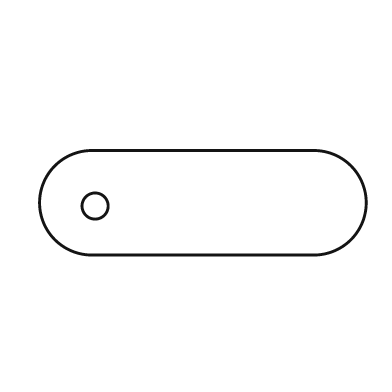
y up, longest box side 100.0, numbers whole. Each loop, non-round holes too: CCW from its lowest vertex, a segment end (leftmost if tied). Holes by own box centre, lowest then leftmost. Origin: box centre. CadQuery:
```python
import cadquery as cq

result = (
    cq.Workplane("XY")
    .moveTo(-34.0, -16.0)
    .lineTo(34.0, -16.0)
    .threePointArc((50.0, 0.0), (34.0, 16.0))
    .lineTo(-34.0, 16.0)
    .threePointArc((-50.0, 0.0), (-34.0, -16.0))
    .close()
    .moveTo(-33.0, -1.0)
    .circle(4.0)
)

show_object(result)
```